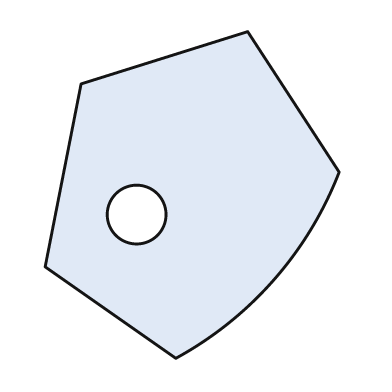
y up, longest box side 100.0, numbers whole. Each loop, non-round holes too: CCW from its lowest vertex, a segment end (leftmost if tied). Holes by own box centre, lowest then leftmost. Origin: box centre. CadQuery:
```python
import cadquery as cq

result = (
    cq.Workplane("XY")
    .moveTo(-5.0, -50.0)
    .threePointArc((25.0, -26.0), (45.0, 7.0))
    .lineTo(17.0, 50.0)
    .lineTo(-34.0, 34.0)
    .lineTo(-45.0, -22.0)
    .close()
    .moveTo(-17.0, -6.0)
    .circle(9.0)
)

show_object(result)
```